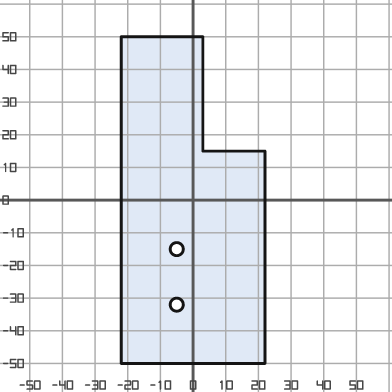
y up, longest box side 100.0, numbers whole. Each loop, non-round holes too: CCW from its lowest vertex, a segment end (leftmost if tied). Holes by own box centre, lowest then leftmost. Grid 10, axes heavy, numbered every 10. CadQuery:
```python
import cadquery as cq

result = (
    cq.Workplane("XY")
    .moveTo(-22.0, -50.0)
    .lineTo(22.0, -50.0)
    .lineTo(22.0, 15.0)
    .lineTo(3.0, 15.0)
    .lineTo(3.0, 50.0)
    .lineTo(-22.0, 50.0)
    .close()
    .moveTo(-5.0, -32.0)
    .circle(2.0)
    .moveTo(-5.0, -15.0)
    .circle(2.0)
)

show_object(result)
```